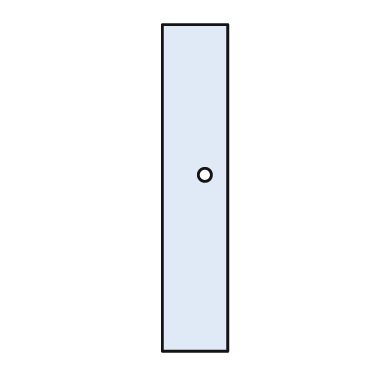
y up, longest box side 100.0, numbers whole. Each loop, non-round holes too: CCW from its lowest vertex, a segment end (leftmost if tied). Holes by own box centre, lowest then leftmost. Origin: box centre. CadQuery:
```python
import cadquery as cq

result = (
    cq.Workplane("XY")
    .moveTo(-10.0, -50.0)
    .lineTo(10.0, -50.0)
    .lineTo(10.0, 50.0)
    .lineTo(-10.0, 50.0)
    .close()
    .moveTo(3.0, 4.0)
    .circle(2.0)
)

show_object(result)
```